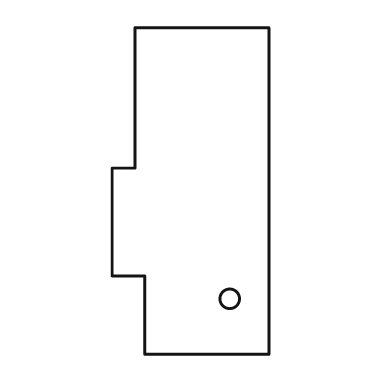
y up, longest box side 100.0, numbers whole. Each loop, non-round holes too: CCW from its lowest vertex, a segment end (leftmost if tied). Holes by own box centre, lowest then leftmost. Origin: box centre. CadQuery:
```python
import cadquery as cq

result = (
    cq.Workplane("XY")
    .moveTo(-14.0, -50.0)
    .lineTo(24.0, -50.0)
    .lineTo(24.0, 50.0)
    .lineTo(-17.0, 50.0)
    .lineTo(-17.0, 7.0)
    .lineTo(-24.0, 7.0)
    .lineTo(-24.0, -26.0)
    .lineTo(-14.0, -26.0)
    .close()
    .moveTo(12.0, -33.0)
    .circle(3.0)
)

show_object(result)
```